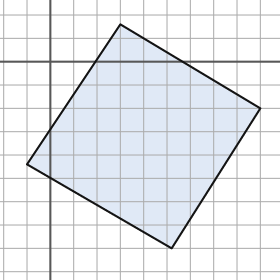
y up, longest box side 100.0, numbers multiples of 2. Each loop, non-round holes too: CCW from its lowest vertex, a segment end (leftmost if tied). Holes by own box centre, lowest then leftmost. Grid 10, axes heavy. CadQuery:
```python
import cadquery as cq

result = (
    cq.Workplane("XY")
    .moveTo(52.0, -80.0)
    .lineTo(90.0, -20.0)
    .lineTo(30.0, 16.0)
    .lineTo(-10.0, -44.0)
    .close()
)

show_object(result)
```